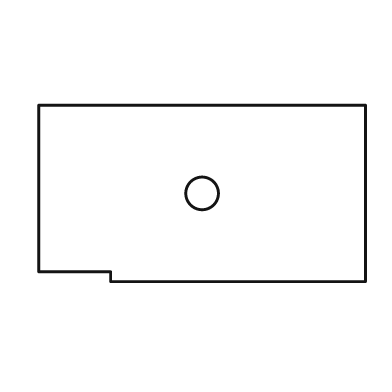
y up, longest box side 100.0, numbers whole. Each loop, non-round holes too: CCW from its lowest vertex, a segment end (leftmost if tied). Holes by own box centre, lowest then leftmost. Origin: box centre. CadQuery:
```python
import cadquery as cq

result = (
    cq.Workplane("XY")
    .moveTo(-28.0, -27.0)
    .lineTo(50.0, -27.0)
    .lineTo(50.0, 27.0)
    .lineTo(-50.0, 27.0)
    .lineTo(-50.0, -24.0)
    .lineTo(-28.0, -24.0)
    .close()
    .moveTo(0.0, 0.0)
    .circle(5.0)
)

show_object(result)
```